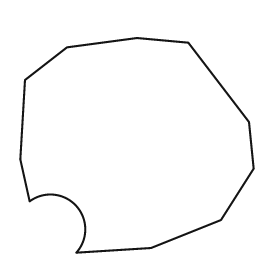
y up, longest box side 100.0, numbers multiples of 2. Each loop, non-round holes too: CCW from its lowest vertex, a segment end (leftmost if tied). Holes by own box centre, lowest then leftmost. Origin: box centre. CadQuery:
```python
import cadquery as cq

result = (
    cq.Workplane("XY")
    .moveTo(-26.0, -46.0)
    .lineTo(6.0, -44.0)
    .lineTo(36.0, -32.0)
    .lineTo(50.0, -10.0)
    .lineTo(48.0, 10.0)
    .lineTo(22.0, 44.0)
    .lineTo(0.0, 46.0)
    .lineTo(-30.0, 42.0)
    .lineTo(-48.0, 28.0)
    .lineTo(-50.0, -6.0)
    .lineTo(-46.0, -24.0)
    .threePointArc((-26.0, -26.0), (-26.0, -46.0))
    .close()
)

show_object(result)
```